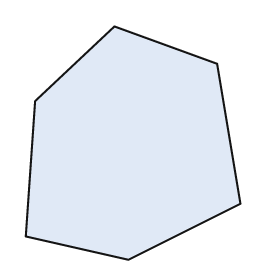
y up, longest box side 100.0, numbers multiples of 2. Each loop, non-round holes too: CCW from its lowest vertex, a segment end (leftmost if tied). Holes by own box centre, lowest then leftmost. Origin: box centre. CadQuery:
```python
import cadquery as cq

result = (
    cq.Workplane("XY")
    .moveTo(-2.0, -50.0)
    .lineTo(46.0, -26.0)
    .lineTo(36.0, 34.0)
    .lineTo(-8.0, 50.0)
    .lineTo(-42.0, 18.0)
    .lineTo(-46.0, -40.0)
    .close()
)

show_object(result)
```